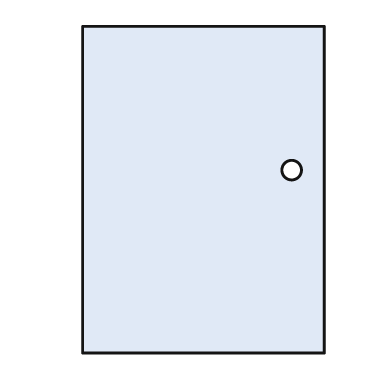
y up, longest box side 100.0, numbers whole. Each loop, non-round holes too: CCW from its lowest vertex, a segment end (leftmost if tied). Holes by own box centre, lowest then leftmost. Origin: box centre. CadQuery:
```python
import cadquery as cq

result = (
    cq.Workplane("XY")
    .moveTo(-37.0, -50.0)
    .lineTo(37.0, -50.0)
    .lineTo(37.0, 50.0)
    .lineTo(-37.0, 50.0)
    .close()
    .moveTo(27.0, 6.0)
    .circle(3.0)
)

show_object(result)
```